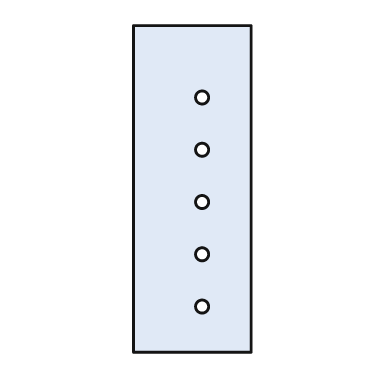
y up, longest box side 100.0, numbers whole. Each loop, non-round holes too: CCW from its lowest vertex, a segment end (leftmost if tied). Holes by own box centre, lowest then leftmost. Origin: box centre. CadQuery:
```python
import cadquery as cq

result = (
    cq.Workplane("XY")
    .moveTo(-18.0, -50.0)
    .lineTo(18.0, -50.0)
    .lineTo(18.0, 50.0)
    .lineTo(-18.0, 50.0)
    .close()
    .moveTo(3.0, -36.0)
    .circle(2.0)
    .moveTo(3.0, -20.0)
    .circle(2.0)
    .moveTo(3.0, -4.0)
    .circle(2.0)
    .moveTo(3.0, 12.0)
    .circle(2.0)
    .moveTo(3.0, 28.0)
    .circle(2.0)
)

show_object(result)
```